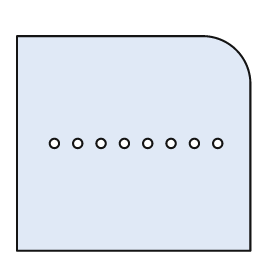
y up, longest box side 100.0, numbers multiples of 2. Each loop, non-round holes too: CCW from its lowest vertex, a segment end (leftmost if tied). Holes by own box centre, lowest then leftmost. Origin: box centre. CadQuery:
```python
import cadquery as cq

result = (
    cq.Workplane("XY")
    .moveTo(-50.0, -46.0)
    .lineTo(50.0, -46.0)
    .lineTo(50.0, 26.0)
    .threePointArc((44.0, 40.0), (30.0, 46.0))
    .lineTo(-50.0, 46.0)
    .close()
    .moveTo(-34.0, 0.0)
    .circle(2.0)
    .moveTo(-24.0, 0.0)
    .circle(2.0)
    .moveTo(-14.0, 0.0)
    .circle(2.0)
    .moveTo(-4.0, 0.0)
    .circle(2.0)
    .moveTo(6.0, 0.0)
    .circle(2.0)
    .moveTo(16.0, 0.0)
    .circle(2.0)
    .moveTo(26.0, 0.0)
    .circle(2.0)
    .moveTo(36.0, 0.0)
    .circle(2.0)
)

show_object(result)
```